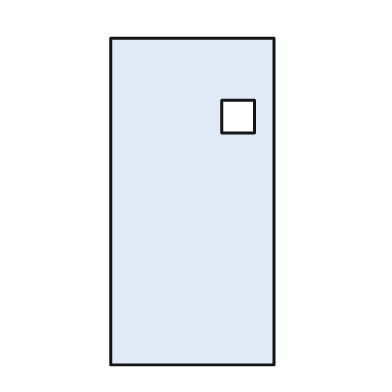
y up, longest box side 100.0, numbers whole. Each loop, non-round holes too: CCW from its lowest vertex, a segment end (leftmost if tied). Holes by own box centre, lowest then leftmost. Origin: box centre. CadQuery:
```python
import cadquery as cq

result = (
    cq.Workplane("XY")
    .moveTo(-25.0, -50.0)
    .lineTo(25.0, -50.0)
    .lineTo(25.0, 50.0)
    .lineTo(-25.0, 50.0)
    .close()
    .moveTo(9.0, 21.0)
    .lineTo(19.0, 21.0)
    .lineTo(19.0, 31.0)
    .lineTo(9.0, 31.0)
    .close()
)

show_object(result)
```